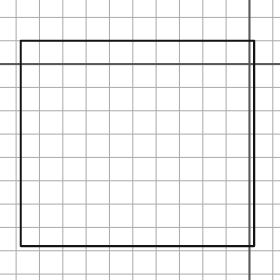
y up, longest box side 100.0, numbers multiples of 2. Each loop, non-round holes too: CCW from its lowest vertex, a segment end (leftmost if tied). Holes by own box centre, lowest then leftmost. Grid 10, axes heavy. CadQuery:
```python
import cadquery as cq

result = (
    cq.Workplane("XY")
    .moveTo(-98.0, -78.0)
    .lineTo(2.0, -78.0)
    .lineTo(2.0, 10.0)
    .lineTo(-98.0, 10.0)
    .close()
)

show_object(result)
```